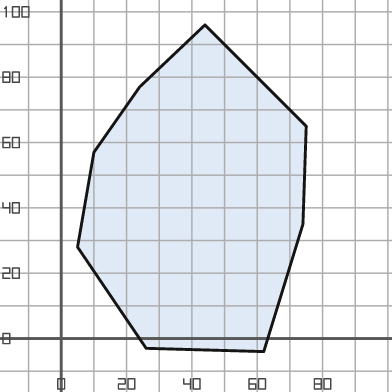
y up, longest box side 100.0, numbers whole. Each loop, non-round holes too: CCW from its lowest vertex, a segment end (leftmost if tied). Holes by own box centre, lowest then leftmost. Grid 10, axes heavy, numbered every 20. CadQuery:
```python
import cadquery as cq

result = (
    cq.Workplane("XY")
    .moveTo(62.0, -4.0)
    .lineTo(74.0, 35.0)
    .lineTo(75.0, 65.0)
    .lineTo(44.0, 96.0)
    .lineTo(24.0, 77.0)
    .lineTo(10.0, 57.0)
    .lineTo(5.0, 28.0)
    .lineTo(26.0, -3.0)
    .close()
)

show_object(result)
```